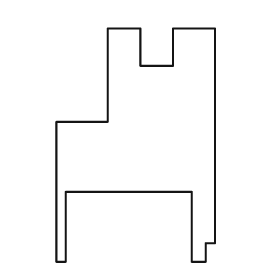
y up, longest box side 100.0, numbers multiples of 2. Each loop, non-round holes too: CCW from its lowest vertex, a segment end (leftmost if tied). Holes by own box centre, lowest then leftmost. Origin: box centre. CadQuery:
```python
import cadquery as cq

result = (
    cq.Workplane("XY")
    .moveTo(-34.0, -50.0)
    .lineTo(-30.0, -50.0)
    .lineTo(-30.0, -20.0)
    .lineTo(24.0, -20.0)
    .lineTo(24.0, -50.0)
    .lineTo(30.0, -50.0)
    .lineTo(30.0, -42.0)
    .lineTo(34.0, -42.0)
    .lineTo(34.0, 50.0)
    .lineTo(16.0, 50.0)
    .lineTo(16.0, 34.0)
    .lineTo(2.0, 34.0)
    .lineTo(2.0, 50.0)
    .lineTo(-12.0, 50.0)
    .lineTo(-12.0, 10.0)
    .lineTo(-34.0, 10.0)
    .close()
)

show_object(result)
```